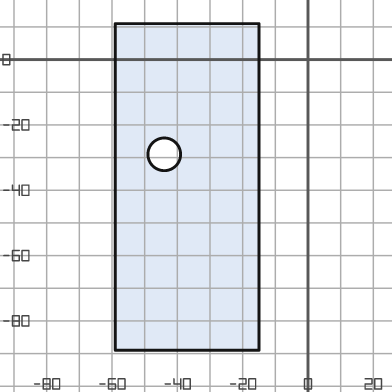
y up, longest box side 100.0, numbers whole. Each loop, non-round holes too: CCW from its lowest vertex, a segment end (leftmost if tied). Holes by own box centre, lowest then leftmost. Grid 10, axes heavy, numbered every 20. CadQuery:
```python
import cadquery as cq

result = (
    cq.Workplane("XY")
    .moveTo(-59.0, -89.0)
    .lineTo(-15.0, -89.0)
    .lineTo(-15.0, 11.0)
    .lineTo(-59.0, 11.0)
    .close()
    .moveTo(-44.0, -29.0)
    .circle(5.0)
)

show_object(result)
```